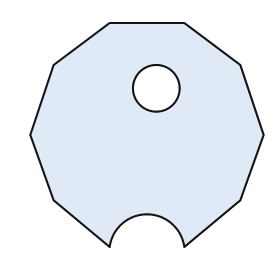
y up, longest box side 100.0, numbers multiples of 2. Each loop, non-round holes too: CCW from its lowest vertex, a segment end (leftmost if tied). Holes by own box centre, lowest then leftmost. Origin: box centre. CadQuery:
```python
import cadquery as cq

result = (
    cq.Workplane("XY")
    .moveTo(-16.0, -48.0)
    .threePointArc((0.0, -34.0), (16.0, -48.0))
    .lineTo(40.0, -28.0)
    .lineTo(50.0, 0.0)
    .lineTo(40.0, 30.0)
    .lineTo(16.0, 48.0)
    .lineTo(-16.0, 48.0)
    .lineTo(-40.0, 30.0)
    .lineTo(-50.0, 0.0)
    .lineTo(-40.0, -28.0)
    .close()
    .moveTo(4.0, 20.0)
    .circle(10.0)
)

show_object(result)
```